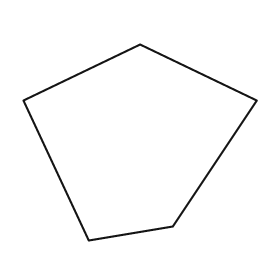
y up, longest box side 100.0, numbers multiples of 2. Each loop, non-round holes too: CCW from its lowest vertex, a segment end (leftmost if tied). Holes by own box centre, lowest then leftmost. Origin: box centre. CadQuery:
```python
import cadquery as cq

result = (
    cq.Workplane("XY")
    .moveTo(-22.0, -42.0)
    .lineTo(14.0, -36.0)
    .lineTo(50.0, 18.0)
    .lineTo(0.0, 42.0)
    .lineTo(-50.0, 18.0)
    .close()
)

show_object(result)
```